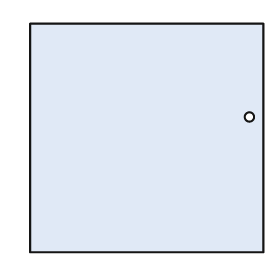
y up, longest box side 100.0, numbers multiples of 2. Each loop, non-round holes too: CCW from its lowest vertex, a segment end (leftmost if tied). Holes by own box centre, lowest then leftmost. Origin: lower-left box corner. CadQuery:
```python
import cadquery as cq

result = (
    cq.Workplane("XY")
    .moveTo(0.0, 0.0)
    .lineTo(100.0, 0.0)
    .lineTo(100.0, 98.0)
    .lineTo(0.0, 98.0)
    .close()
    .moveTo(94.0, 58.0)
    .circle(2.0)
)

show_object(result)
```